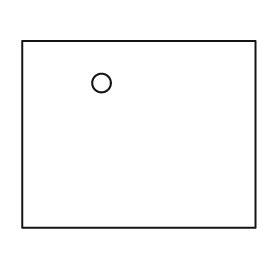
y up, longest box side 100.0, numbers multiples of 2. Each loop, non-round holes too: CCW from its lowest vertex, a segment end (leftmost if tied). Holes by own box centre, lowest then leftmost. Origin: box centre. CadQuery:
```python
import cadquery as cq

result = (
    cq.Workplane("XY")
    .moveTo(-50.0, -40.0)
    .lineTo(50.0, -40.0)
    .lineTo(50.0, 40.0)
    .lineTo(-50.0, 40.0)
    .close()
    .moveTo(-16.0, 22.0)
    .circle(4.0)
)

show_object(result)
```